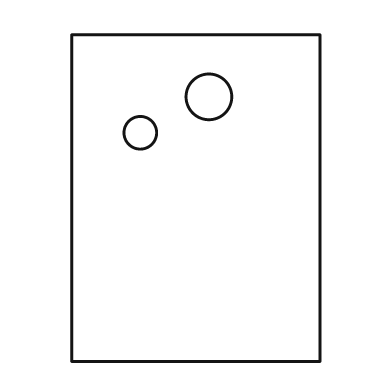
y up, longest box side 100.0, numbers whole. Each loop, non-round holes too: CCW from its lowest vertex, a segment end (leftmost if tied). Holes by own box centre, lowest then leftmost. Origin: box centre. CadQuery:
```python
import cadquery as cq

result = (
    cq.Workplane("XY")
    .moveTo(-38.0, -50.0)
    .lineTo(38.0, -50.0)
    .lineTo(38.0, 50.0)
    .lineTo(-38.0, 50.0)
    .close()
    .moveTo(-17.0, 20.0)
    .circle(5.0)
    .moveTo(4.0, 31.0)
    .circle(7.0)
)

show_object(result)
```